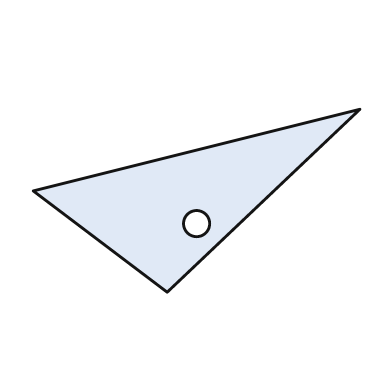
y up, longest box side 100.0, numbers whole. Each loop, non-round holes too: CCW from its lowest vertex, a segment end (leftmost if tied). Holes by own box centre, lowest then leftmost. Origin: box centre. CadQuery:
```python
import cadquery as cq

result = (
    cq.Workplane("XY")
    .moveTo(-9.0, -28.0)
    .lineTo(50.0, 28.0)
    .lineTo(-50.0, 3.0)
    .close()
    .moveTo(0.0, -7.0)
    .circle(4.0)
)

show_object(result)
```